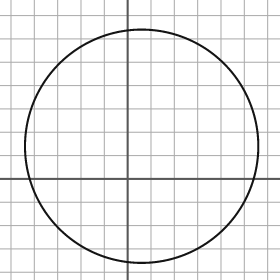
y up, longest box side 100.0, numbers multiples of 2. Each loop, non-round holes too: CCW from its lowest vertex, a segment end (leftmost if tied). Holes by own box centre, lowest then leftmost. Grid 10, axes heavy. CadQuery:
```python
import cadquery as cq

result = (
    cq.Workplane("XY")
    .moveTo(6.0, 14.0)
    .circle(50.0)
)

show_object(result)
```